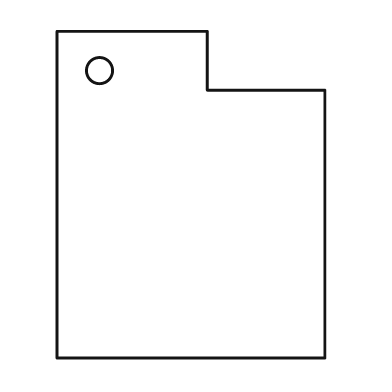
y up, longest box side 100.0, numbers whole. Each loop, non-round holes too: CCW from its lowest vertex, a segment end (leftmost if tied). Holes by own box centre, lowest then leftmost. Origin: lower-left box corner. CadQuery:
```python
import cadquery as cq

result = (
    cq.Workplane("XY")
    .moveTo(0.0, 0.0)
    .lineTo(82.0, 0.0)
    .lineTo(82.0, 82.0)
    .lineTo(46.0, 82.0)
    .lineTo(46.0, 100.0)
    .lineTo(0.0, 100.0)
    .close()
    .moveTo(13.0, 88.0)
    .circle(4.0)
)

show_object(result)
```